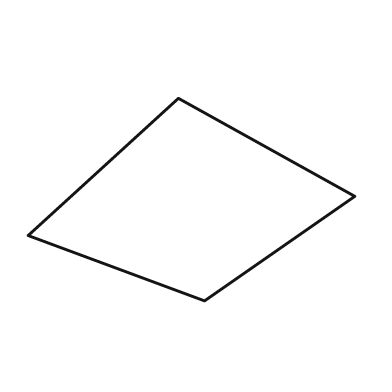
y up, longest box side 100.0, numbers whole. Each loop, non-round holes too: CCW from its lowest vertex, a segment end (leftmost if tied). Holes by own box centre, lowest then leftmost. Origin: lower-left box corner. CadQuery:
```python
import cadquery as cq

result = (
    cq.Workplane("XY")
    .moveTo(54.0, 0.0)
    .lineTo(100.0, 32.0)
    .lineTo(46.0, 62.0)
    .lineTo(0.0, 20.0)
    .close()
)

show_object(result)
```